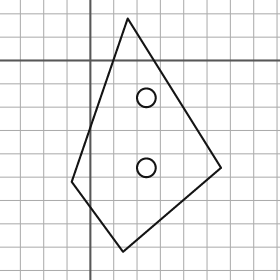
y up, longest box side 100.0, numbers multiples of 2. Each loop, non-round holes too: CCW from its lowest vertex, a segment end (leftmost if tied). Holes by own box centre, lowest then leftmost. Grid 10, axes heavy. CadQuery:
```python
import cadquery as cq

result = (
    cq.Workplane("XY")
    .moveTo(14.0, -82.0)
    .lineTo(56.0, -46.0)
    .lineTo(16.0, 18.0)
    .lineTo(-8.0, -52.0)
    .close()
    .moveTo(24.0, -46.0)
    .circle(4.0)
    .moveTo(24.0, -16.0)
    .circle(4.0)
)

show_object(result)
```